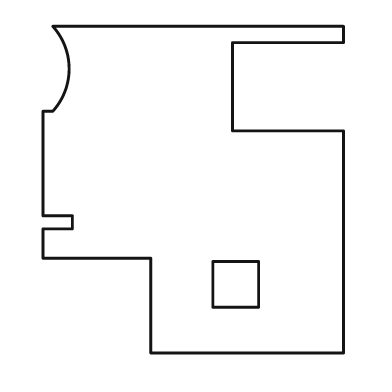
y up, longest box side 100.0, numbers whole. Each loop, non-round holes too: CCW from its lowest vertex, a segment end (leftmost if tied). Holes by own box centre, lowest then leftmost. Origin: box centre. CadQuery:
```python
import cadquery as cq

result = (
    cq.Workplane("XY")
    .moveTo(-13.0, -50.0)
    .lineTo(46.0, -50.0)
    .lineTo(46.0, 18.0)
    .lineTo(12.0, 18.0)
    .lineTo(12.0, 45.0)
    .lineTo(46.0, 45.0)
    .lineTo(46.0, 50.0)
    .lineTo(-43.0, 50.0)
    .threePointArc((-38.0, 37.0), (-43.0, 24.0))
    .lineTo(-46.0, 24.0)
    .lineTo(-46.0, -8.0)
    .lineTo(-37.0, -8.0)
    .lineTo(-37.0, -12.0)
    .lineTo(-46.0, -12.0)
    .lineTo(-46.0, -21.0)
    .lineTo(-13.0, -21.0)
    .close()
    .moveTo(6.0, -36.0)
    .lineTo(20.0, -36.0)
    .lineTo(20.0, -22.0)
    .lineTo(6.0, -22.0)
    .close()
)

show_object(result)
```